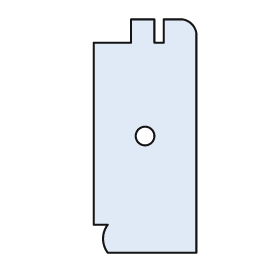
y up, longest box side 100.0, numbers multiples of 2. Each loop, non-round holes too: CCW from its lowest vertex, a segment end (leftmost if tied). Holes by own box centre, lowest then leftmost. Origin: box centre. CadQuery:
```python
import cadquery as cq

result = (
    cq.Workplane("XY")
    .moveTo(-16.0, -50.0)
    .lineTo(22.0, -50.0)
    .lineTo(22.0, 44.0)
    .threePointArc((20.0, 48.0), (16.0, 50.0))
    .lineTo(8.0, 50.0)
    .lineTo(8.0, 40.0)
    .lineTo(4.0, 40.0)
    .lineTo(4.0, 50.0)
    .lineTo(-6.0, 50.0)
    .lineTo(-6.0, 40.0)
    .lineTo(-22.0, 40.0)
    .lineTo(-22.0, -38.0)
    .lineTo(-16.0, -38.0)
    .threePointArc((-18.0, -44.0), (-16.0, -50.0))
    .close()
    .moveTo(0.0, 0.0)
    .circle(4.0)
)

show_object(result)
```